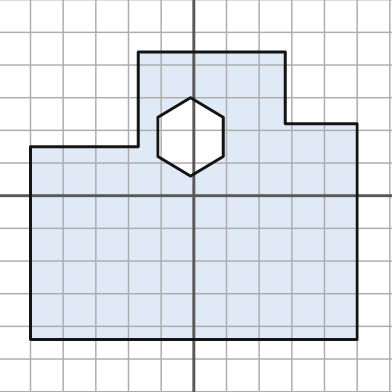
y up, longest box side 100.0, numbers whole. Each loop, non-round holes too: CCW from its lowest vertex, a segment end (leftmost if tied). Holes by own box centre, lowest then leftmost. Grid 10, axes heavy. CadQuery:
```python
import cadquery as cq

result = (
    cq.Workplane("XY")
    .moveTo(-50.0, -44.0)
    .lineTo(50.0, -44.0)
    .lineTo(50.0, 22.0)
    .lineTo(28.0, 22.0)
    .lineTo(28.0, 44.0)
    .lineTo(-17.0, 44.0)
    .lineTo(-17.0, 15.0)
    .lineTo(-50.0, 15.0)
    .close()
    .moveTo(-1.0, 6.0)
    .lineTo(9.0, 12.0)
    .lineTo(9.0, 24.0)
    .lineTo(-1.0, 30.0)
    .lineTo(-11.0, 24.0)
    .lineTo(-11.0, 12.0)
    .close()
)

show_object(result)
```